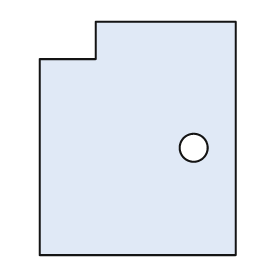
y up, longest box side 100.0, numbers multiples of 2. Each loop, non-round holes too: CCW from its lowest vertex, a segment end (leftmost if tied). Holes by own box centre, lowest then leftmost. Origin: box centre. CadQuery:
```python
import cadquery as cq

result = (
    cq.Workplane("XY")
    .moveTo(-42.0, -50.0)
    .lineTo(42.0, -50.0)
    .lineTo(42.0, 50.0)
    .lineTo(-18.0, 50.0)
    .lineTo(-18.0, 34.0)
    .lineTo(-42.0, 34.0)
    .close()
    .moveTo(24.0, -4.0)
    .circle(6.0)
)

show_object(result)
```